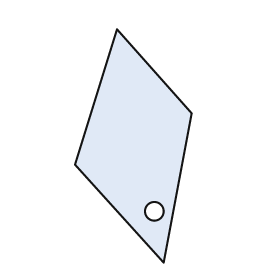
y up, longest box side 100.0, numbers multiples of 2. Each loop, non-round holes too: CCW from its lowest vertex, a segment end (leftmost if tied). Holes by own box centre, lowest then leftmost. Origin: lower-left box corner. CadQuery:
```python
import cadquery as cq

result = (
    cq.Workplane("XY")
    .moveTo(38.0, 0.0)
    .lineTo(50.0, 64.0)
    .lineTo(18.0, 100.0)
    .lineTo(0.0, 42.0)
    .close()
    .moveTo(34.0, 22.0)
    .circle(4.0)
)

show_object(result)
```